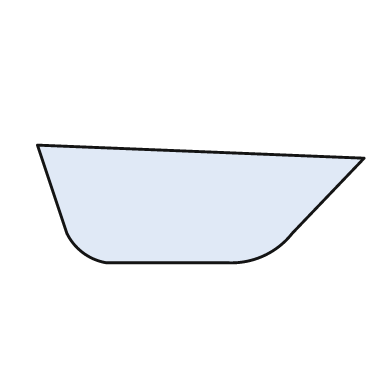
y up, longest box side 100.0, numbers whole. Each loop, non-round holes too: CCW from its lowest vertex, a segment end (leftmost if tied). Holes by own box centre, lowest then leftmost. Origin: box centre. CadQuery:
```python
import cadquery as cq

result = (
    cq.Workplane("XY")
    .moveTo(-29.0, -18.0)
    .lineTo(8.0, -18.0)
    .threePointArc((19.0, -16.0), (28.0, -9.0))
    .lineTo(50.0, 14.0)
    .lineTo(-50.0, 18.0)
    .lineTo(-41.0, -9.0)
    .threePointArc((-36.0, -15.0), (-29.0, -18.0))
    .close()
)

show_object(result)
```